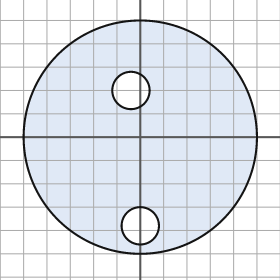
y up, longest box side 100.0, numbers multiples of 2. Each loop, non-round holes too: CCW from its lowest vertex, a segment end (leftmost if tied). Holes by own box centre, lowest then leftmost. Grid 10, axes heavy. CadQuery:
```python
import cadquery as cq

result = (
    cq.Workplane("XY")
    .moveTo(0.0, 0.0)
    .circle(50.0)
    .moveTo(0.0, -38.0)
    .circle(8.0)
    .moveTo(-4.0, 20.0)
    .circle(8.0)
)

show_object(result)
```